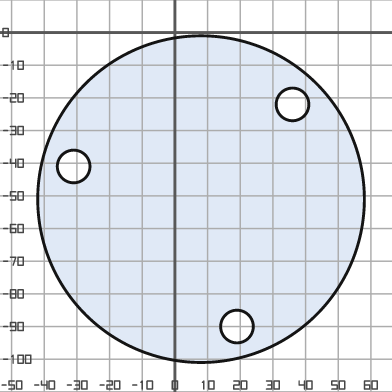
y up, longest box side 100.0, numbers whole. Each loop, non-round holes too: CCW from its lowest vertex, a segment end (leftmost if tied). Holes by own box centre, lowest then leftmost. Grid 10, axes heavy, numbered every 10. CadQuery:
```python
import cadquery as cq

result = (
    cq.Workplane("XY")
    .moveTo(8.0, -51.0)
    .circle(50.0)
    .moveTo(19.0, -90.0)
    .circle(5.0)
    .moveTo(-31.0, -41.0)
    .circle(5.0)
    .moveTo(36.0, -22.0)
    .circle(5.0)
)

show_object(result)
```